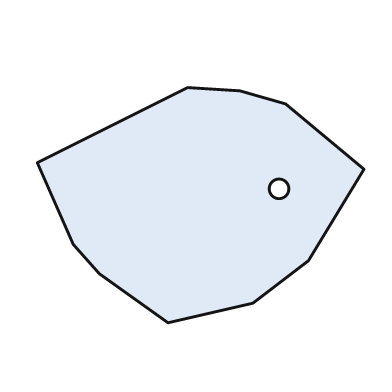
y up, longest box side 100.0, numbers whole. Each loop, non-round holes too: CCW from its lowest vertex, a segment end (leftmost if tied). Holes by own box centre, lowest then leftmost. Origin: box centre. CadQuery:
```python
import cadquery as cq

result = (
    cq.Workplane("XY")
    .moveTo(-10.0, -36.0)
    .lineTo(16.0, -30.0)
    .lineTo(33.0, -17.0)
    .lineTo(50.0, 11.0)
    .lineTo(26.0, 31.0)
    .lineTo(12.0, 35.0)
    .lineTo(-4.0, 36.0)
    .lineTo(-50.0, 13.0)
    .lineTo(-39.0, -12.0)
    .lineTo(-31.0, -21.0)
    .close()
    .moveTo(24.0, 5.0)
    .circle(3.0)
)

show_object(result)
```